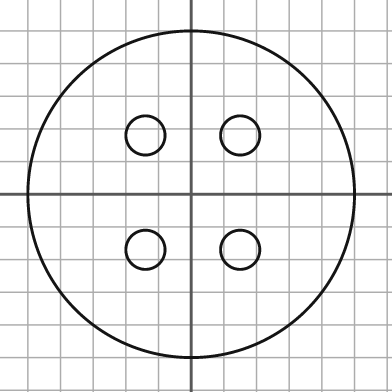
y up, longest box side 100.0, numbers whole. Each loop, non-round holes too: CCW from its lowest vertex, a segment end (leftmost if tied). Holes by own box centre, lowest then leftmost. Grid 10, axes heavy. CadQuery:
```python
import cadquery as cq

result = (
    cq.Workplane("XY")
    .moveTo(0.0, 0.0)
    .circle(50.0)
    .moveTo(-14.0, -17.0)
    .circle(6.0)
    .moveTo(15.0, -17.0)
    .circle(6.0)
    .moveTo(-14.0, 18.0)
    .circle(6.0)
    .moveTo(15.0, 18.0)
    .circle(6.0)
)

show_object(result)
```